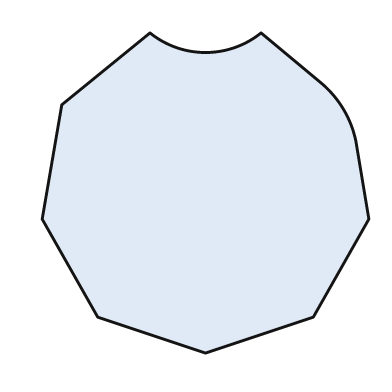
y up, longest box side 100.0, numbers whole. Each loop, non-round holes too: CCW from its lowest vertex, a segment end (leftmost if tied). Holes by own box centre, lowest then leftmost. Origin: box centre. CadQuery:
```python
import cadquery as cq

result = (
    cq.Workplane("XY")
    .moveTo(0.0, -49.0)
    .lineTo(33.0, -38.0)
    .lineTo(50.0, -8.0)
    .lineTo(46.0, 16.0)
    .threePointArc((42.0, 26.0), (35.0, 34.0))
    .lineTo(17.0, 49.0)
    .threePointArc((0.0, 43.0), (-17.0, 49.0))
    .lineTo(-44.0, 27.0)
    .lineTo(-50.0, -8.0)
    .lineTo(-33.0, -38.0)
    .close()
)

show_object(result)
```